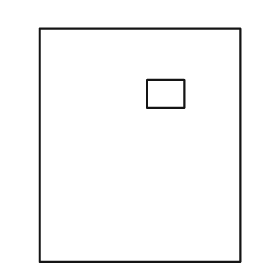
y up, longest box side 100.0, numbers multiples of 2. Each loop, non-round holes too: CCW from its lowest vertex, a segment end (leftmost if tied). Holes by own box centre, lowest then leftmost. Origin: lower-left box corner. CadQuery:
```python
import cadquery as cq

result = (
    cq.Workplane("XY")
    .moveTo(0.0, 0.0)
    .lineTo(86.0, 0.0)
    .lineTo(86.0, 100.0)
    .lineTo(0.0, 100.0)
    .close()
    .moveTo(46.0, 66.0)
    .lineTo(62.0, 66.0)
    .lineTo(62.0, 78.0)
    .lineTo(46.0, 78.0)
    .close()
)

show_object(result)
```